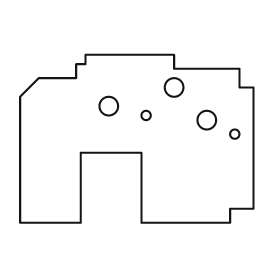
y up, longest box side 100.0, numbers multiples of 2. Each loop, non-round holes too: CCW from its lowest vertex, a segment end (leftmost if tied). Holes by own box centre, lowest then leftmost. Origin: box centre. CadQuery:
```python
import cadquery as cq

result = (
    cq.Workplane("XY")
    .moveTo(-50.0, -36.0)
    .lineTo(-24.0, -36.0)
    .lineTo(-24.0, -6.0)
    .lineTo(2.0, -6.0)
    .lineTo(2.0, -36.0)
    .lineTo(40.0, -36.0)
    .lineTo(40.0, -30.0)
    .lineTo(50.0, -30.0)
    .lineTo(50.0, 22.0)
    .lineTo(44.0, 22.0)
    .lineTo(44.0, 30.0)
    .lineTo(16.0, 30.0)
    .lineTo(16.0, 36.0)
    .lineTo(-22.0, 36.0)
    .lineTo(-22.0, 32.0)
    .lineTo(-26.0, 32.0)
    .lineTo(-26.0, 26.0)
    .lineTo(-42.0, 26.0)
    .lineTo(-50.0, 18.0)
    .close()
    .moveTo(42.0, 2.0)
    .circle(2.0)
    .moveTo(30.0, 8.0)
    .circle(4.0)
    .moveTo(4.0, 10.0)
    .circle(2.0)
    .moveTo(-12.0, 14.0)
    .circle(4.0)
    .moveTo(16.0, 22.0)
    .circle(4.0)
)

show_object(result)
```